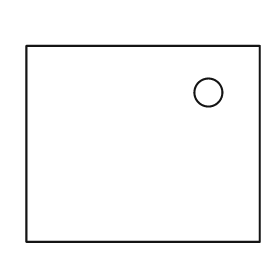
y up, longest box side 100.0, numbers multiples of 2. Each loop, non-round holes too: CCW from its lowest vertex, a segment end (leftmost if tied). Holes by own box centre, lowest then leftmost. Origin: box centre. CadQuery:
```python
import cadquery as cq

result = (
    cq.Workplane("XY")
    .moveTo(-50.0, -42.0)
    .lineTo(50.0, -42.0)
    .lineTo(50.0, 42.0)
    .lineTo(-50.0, 42.0)
    .close()
    .moveTo(28.0, 22.0)
    .circle(6.0)
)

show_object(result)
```